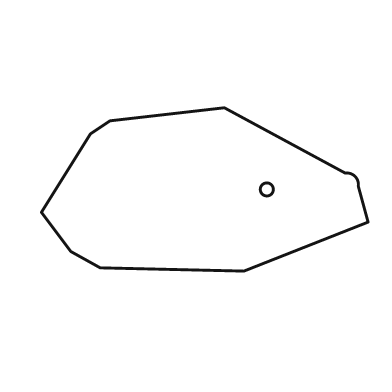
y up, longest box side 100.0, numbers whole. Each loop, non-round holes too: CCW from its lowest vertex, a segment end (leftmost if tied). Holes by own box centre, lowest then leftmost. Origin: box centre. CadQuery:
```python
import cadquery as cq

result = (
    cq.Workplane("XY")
    .moveTo(12.0, -25.0)
    .lineTo(50.0, -10.0)
    .lineTo(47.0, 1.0)
    .threePointArc((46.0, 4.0), (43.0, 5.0))
    .lineTo(6.0, 25.0)
    .lineTo(-29.0, 21.0)
    .lineTo(-35.0, 17.0)
    .lineTo(-50.0, -7.0)
    .lineTo(-41.0, -19.0)
    .lineTo(-32.0, -24.0)
    .close()
    .moveTo(19.0, 0.0)
    .circle(2.0)
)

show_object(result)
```